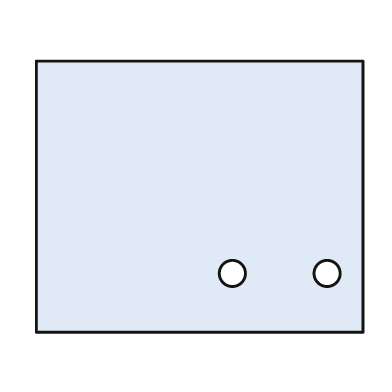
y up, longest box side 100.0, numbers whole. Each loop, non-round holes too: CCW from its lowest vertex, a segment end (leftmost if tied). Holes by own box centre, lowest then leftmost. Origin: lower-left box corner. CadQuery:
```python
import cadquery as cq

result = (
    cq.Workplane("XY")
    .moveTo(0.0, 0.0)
    .lineTo(100.0, 0.0)
    .lineTo(100.0, 83.0)
    .lineTo(0.0, 83.0)
    .close()
    .moveTo(60.0, 18.0)
    .circle(4.0)
    .moveTo(89.0, 18.0)
    .circle(4.0)
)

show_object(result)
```